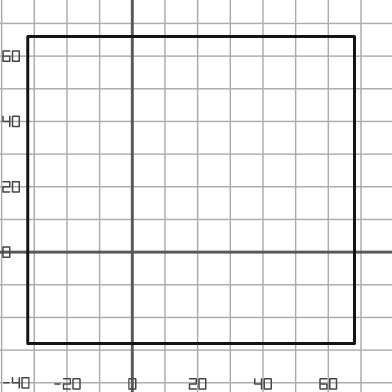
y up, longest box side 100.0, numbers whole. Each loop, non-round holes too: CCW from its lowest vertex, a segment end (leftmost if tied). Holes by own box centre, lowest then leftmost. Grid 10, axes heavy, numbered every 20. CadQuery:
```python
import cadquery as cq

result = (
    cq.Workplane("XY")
    .moveTo(-32.0, -28.0)
    .lineTo(68.0, -28.0)
    .lineTo(68.0, 66.0)
    .lineTo(-32.0, 66.0)
    .close()
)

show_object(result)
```